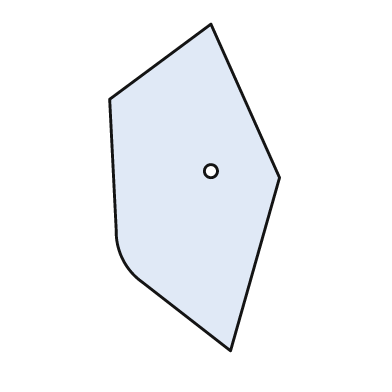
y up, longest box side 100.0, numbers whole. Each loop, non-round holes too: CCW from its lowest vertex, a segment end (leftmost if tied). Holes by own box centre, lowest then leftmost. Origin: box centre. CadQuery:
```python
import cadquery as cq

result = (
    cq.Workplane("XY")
    .moveTo(11.0, -50.0)
    .lineTo(26.0, 3.0)
    .lineTo(5.0, 50.0)
    .lineTo(-26.0, 27.0)
    .lineTo(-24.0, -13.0)
    .threePointArc((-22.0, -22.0), (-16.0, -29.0))
    .close()
    .moveTo(5.0, 5.0)
    .circle(2.0)
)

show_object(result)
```